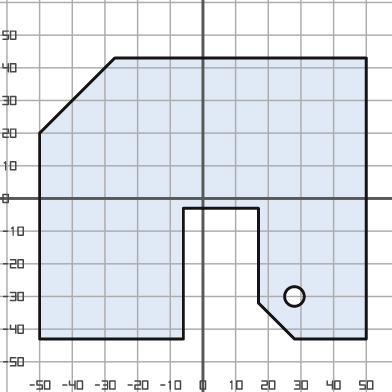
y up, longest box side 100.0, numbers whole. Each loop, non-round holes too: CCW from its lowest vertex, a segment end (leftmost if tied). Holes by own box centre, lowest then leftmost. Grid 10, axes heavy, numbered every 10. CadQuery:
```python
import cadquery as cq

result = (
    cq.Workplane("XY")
    .moveTo(-50.0, -43.0)
    .lineTo(-6.0, -43.0)
    .lineTo(-6.0, -3.0)
    .lineTo(17.0, -3.0)
    .lineTo(17.0, -32.0)
    .lineTo(28.0, -43.0)
    .lineTo(50.0, -43.0)
    .lineTo(50.0, 43.0)
    .lineTo(-27.0, 43.0)
    .lineTo(-50.0, 20.0)
    .close()
    .moveTo(28.0, -30.0)
    .circle(3.0)
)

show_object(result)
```